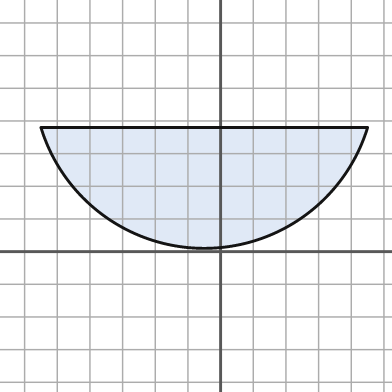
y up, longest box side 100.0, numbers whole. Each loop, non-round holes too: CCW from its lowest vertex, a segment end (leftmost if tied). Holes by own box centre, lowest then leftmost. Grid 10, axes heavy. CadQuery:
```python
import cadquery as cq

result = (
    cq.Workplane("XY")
    .moveTo(-55.0, 38.0)
    .threePointArc((-5.0, 1.0), (45.0, 38.0))
    .close()
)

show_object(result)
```